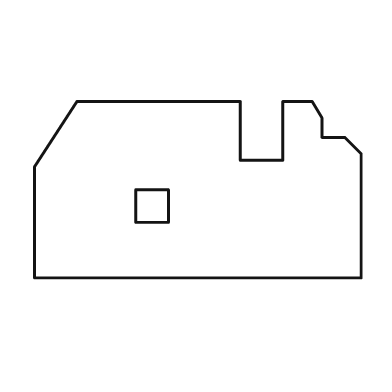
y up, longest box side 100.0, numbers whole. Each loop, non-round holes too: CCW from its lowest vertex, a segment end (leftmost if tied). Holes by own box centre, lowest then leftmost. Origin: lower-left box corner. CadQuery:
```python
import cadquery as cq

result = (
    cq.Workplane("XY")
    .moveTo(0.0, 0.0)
    .lineTo(100.0, 0.0)
    .lineTo(100.0, 38.0)
    .lineTo(95.0, 43.0)
    .lineTo(88.0, 43.0)
    .lineTo(88.0, 49.0)
    .lineTo(85.0, 54.0)
    .lineTo(76.0, 54.0)
    .lineTo(76.0, 36.0)
    .lineTo(63.0, 36.0)
    .lineTo(63.0, 54.0)
    .lineTo(13.0, 54.0)
    .lineTo(0.0, 34.0)
    .close()
    .moveTo(31.0, 17.0)
    .lineTo(41.0, 17.0)
    .lineTo(41.0, 27.0)
    .lineTo(31.0, 27.0)
    .close()
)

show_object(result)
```